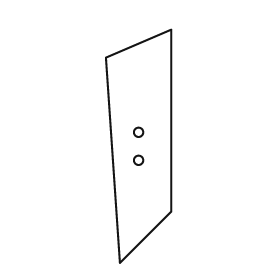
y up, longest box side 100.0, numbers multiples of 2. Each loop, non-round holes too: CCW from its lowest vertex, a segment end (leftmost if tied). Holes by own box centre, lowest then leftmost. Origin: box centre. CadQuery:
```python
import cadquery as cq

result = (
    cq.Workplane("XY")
    .moveTo(-8.0, -50.0)
    .lineTo(14.0, -28.0)
    .lineTo(14.0, 50.0)
    .lineTo(-14.0, 38.0)
    .close()
    .moveTo(0.0, -6.0)
    .circle(2.0)
    .moveTo(0.0, 6.0)
    .circle(2.0)
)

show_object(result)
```